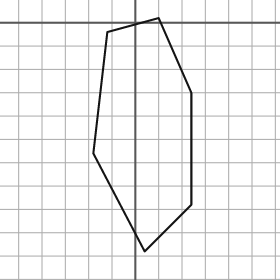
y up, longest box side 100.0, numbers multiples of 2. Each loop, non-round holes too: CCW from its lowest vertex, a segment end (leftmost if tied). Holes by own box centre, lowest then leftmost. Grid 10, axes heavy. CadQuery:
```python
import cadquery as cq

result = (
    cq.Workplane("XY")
    .moveTo(4.0, -98.0)
    .lineTo(24.0, -78.0)
    .lineTo(24.0, -30.0)
    .lineTo(10.0, 2.0)
    .lineTo(-12.0, -4.0)
    .lineTo(-18.0, -56.0)
    .close()
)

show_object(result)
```